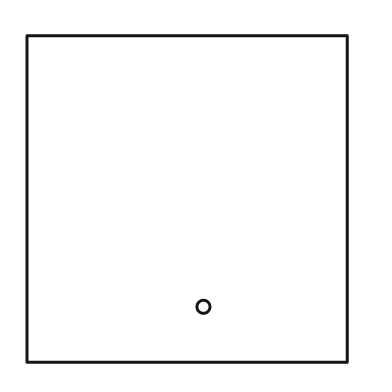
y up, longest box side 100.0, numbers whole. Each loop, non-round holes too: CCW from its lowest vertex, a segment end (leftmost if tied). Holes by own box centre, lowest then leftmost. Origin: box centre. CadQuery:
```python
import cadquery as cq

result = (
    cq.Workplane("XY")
    .moveTo(-49.0, -50.0)
    .lineTo(49.0, -50.0)
    .lineTo(49.0, 50.0)
    .lineTo(-49.0, 50.0)
    .close()
    .moveTo(5.0, -33.0)
    .circle(2.0)
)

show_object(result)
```